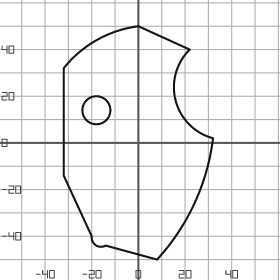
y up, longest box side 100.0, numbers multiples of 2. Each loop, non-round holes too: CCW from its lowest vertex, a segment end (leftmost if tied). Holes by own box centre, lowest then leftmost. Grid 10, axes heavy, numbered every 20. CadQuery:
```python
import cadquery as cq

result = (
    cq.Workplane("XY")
    .moveTo(8.0, -50.0)
    .threePointArc((24.0, -26.0), (32.0, 2.0))
    .threePointArc((16.0, 18.0), (22.0, 40.0))
    .lineTo(0.0, 50.0)
    .threePointArc((-18.0, 44.0), (-32.0, 32.0))
    .lineTo(-32.0, -14.0)
    .lineTo(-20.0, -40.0)
    .threePointArc((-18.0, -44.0), (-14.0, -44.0))
    .close()
    .moveTo(-18.0, 14.0)
    .circle(6.0)
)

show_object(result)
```